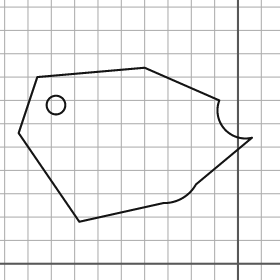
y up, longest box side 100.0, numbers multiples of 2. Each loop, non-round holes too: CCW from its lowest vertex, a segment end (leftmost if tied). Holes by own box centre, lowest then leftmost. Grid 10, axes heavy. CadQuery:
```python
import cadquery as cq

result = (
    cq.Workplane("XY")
    .moveTo(-68.0, 18.0)
    .lineTo(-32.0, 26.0)
    .threePointArc((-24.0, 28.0), (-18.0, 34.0))
    .lineTo(6.0, 54.0)
    .threePointArc((-6.0, 58.0), (-8.0, 70.0))
    .lineTo(-40.0, 84.0)
    .lineTo(-86.0, 80.0)
    .lineTo(-94.0, 56.0)
    .close()
    .moveTo(-78.0, 68.0)
    .circle(4.0)
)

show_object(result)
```